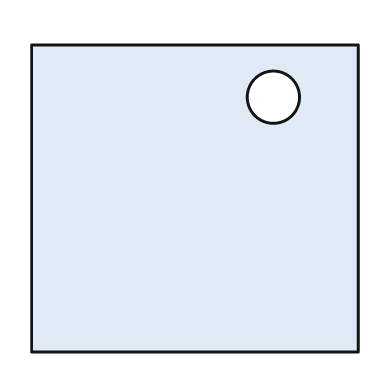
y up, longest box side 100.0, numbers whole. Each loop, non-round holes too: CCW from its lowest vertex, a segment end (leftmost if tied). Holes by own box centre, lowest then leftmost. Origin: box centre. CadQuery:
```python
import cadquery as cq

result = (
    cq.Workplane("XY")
    .moveTo(-50.0, -47.0)
    .lineTo(50.0, -47.0)
    .lineTo(50.0, 47.0)
    .lineTo(-50.0, 47.0)
    .close()
    .moveTo(24.0, 31.0)
    .circle(8.0)
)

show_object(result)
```